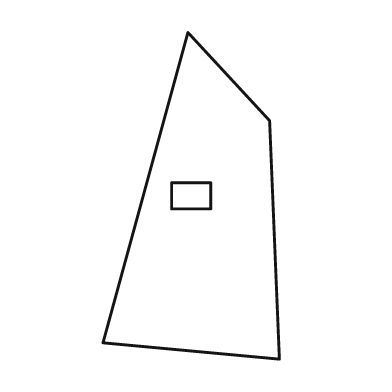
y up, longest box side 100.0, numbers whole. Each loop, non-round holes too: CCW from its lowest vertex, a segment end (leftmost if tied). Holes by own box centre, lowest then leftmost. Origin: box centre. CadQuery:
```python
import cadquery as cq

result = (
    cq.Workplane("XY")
    .moveTo(27.0, -50.0)
    .lineTo(24.0, 23.0)
    .lineTo(-1.0, 50.0)
    .lineTo(-27.0, -45.0)
    .close()
    .moveTo(-6.0, -4.0)
    .lineTo(6.0, -4.0)
    .lineTo(6.0, 4.0)
    .lineTo(-6.0, 4.0)
    .close()
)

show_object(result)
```